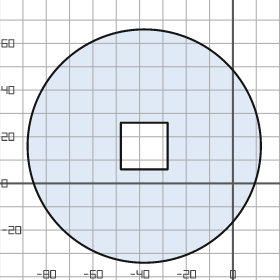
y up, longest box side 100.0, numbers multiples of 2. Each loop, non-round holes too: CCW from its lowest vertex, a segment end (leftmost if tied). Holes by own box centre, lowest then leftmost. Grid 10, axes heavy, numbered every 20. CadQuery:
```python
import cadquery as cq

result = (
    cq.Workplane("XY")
    .moveTo(-38.0, 16.0)
    .circle(50.0)
    .moveTo(-48.0, 6.0)
    .lineTo(-28.0, 6.0)
    .lineTo(-28.0, 26.0)
    .lineTo(-48.0, 26.0)
    .close()
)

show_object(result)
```